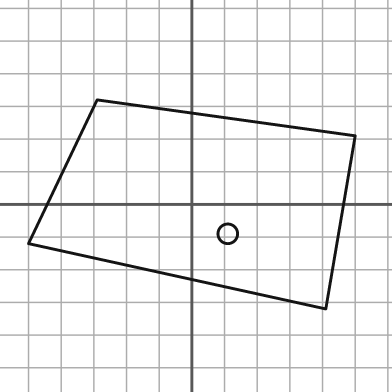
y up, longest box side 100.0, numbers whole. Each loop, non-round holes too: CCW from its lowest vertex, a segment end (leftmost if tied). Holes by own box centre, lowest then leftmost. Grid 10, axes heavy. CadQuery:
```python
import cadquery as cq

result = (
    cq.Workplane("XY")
    .moveTo(41.0, -32.0)
    .lineTo(50.0, 21.0)
    .lineTo(-29.0, 32.0)
    .lineTo(-50.0, -12.0)
    .close()
    .moveTo(11.0, -9.0)
    .circle(3.0)
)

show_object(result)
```